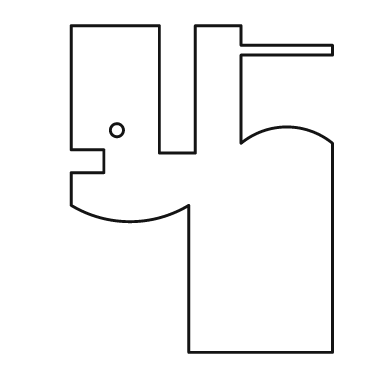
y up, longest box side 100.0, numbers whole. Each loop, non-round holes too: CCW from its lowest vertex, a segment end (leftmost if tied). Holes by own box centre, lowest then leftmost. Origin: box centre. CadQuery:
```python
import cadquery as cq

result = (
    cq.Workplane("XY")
    .moveTo(-4.0, -50.0)
    .lineTo(40.0, -50.0)
    .lineTo(40.0, 14.0)
    .threePointArc((26.0, 19.0), (12.0, 14.0))
    .lineTo(12.0, 41.0)
    .lineTo(40.0, 41.0)
    .lineTo(40.0, 44.0)
    .lineTo(12.0, 44.0)
    .lineTo(12.0, 50.0)
    .lineTo(-2.0, 50.0)
    .lineTo(-2.0, 11.0)
    .lineTo(-13.0, 11.0)
    .lineTo(-13.0, 50.0)
    .lineTo(-40.0, 50.0)
    .lineTo(-40.0, 12.0)
    .lineTo(-30.0, 12.0)
    .lineTo(-30.0, 5.0)
    .lineTo(-40.0, 5.0)
    .lineTo(-40.0, -5.0)
    .threePointArc((-22.0, -10.0), (-4.0, -5.0))
    .close()
    .moveTo(-26.0, 18.0)
    .circle(2.0)
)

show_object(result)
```